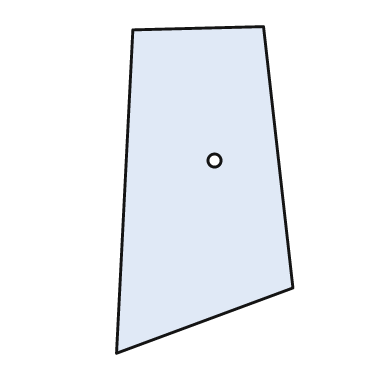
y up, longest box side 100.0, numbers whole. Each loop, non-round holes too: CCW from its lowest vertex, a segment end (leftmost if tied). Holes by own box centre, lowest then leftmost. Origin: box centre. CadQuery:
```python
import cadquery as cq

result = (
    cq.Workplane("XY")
    .moveTo(-27.0, -50.0)
    .lineTo(27.0, -30.0)
    .lineTo(18.0, 50.0)
    .lineTo(-22.0, 49.0)
    .close()
    .moveTo(3.0, 9.0)
    .circle(2.0)
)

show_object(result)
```